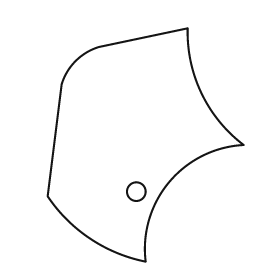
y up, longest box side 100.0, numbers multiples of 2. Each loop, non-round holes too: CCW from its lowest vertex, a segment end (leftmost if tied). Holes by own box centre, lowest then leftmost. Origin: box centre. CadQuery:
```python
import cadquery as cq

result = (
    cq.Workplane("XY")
    .moveTo(0.0, -50.0)
    .threePointArc((10.0, -16.0), (42.0, 0.0))
    .threePointArc((24.0, 22.0), (18.0, 50.0))
    .lineTo(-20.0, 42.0)
    .threePointArc((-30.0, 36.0), (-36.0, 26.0))
    .lineTo(-42.0, -22.0)
    .threePointArc((-24.0, -40.0), (0.0, -50.0))
    .close()
    .moveTo(-4.0, -20.0)
    .circle(4.0)
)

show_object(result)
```